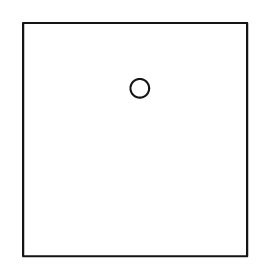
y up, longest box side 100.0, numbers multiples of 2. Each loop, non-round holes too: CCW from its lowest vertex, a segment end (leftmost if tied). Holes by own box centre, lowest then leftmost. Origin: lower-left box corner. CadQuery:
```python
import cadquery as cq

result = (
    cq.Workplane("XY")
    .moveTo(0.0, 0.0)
    .lineTo(96.0, 0.0)
    .lineTo(96.0, 100.0)
    .lineTo(0.0, 100.0)
    .close()
    .moveTo(50.0, 72.0)
    .circle(4.0)
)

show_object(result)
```